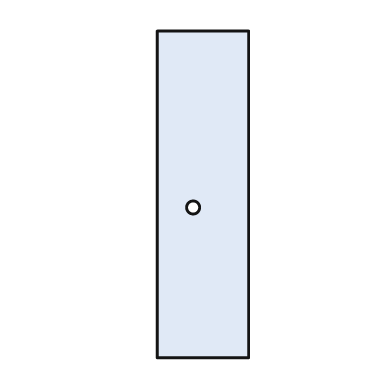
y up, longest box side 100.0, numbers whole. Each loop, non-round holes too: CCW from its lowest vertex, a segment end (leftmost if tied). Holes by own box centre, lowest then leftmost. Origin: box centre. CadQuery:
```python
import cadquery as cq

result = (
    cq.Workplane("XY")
    .moveTo(-14.0, -50.0)
    .lineTo(14.0, -50.0)
    .lineTo(14.0, 50.0)
    .lineTo(-14.0, 50.0)
    .close()
    .moveTo(-3.0, -4.0)
    .circle(2.0)
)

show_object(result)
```